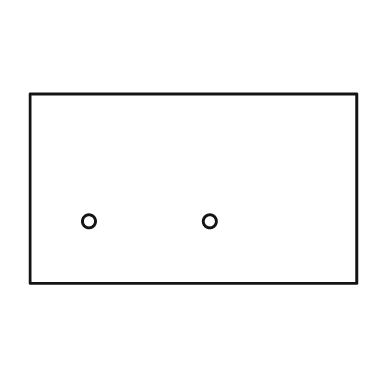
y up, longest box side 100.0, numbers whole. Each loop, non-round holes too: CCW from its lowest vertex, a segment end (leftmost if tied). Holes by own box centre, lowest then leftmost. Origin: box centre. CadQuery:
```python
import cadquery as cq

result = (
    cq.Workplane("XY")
    .moveTo(-50.0, -29.0)
    .lineTo(50.0, -29.0)
    .lineTo(50.0, 29.0)
    .lineTo(-50.0, 29.0)
    .close()
    .moveTo(-32.0, -10.0)
    .circle(2.0)
    .moveTo(5.0, -10.0)
    .circle(2.0)
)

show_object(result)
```